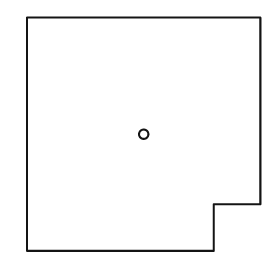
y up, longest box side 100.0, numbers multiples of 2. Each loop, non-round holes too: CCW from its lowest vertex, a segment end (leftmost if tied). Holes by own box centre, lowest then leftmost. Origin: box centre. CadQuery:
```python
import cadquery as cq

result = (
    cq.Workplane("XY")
    .moveTo(-50.0, -50.0)
    .lineTo(30.0, -50.0)
    .lineTo(30.0, -30.0)
    .lineTo(50.0, -30.0)
    .lineTo(50.0, 50.0)
    .lineTo(-50.0, 50.0)
    .close()
    .moveTo(0.0, 0.0)
    .circle(2.0)
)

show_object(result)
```